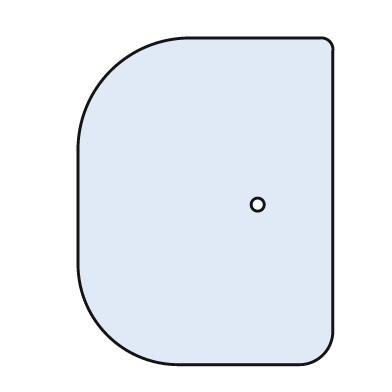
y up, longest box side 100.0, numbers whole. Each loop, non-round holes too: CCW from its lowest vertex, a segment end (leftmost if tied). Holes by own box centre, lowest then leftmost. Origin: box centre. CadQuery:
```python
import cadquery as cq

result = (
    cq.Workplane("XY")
    .moveTo(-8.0, -50.0)
    .lineTo(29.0, -50.0)
    .threePointArc((36.0, -47.0), (39.0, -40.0))
    .lineTo(39.0, 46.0)
    .threePointArc((38.0, 49.0), (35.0, 50.0))
    .lineTo(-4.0, 50.0)
    .threePointArc((-29.0, 40.0), (-39.0, 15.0))
    .lineTo(-39.0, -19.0)
    .threePointArc((-30.0, -41.0), (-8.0, -50.0))
    .close()
    .moveTo(16.0, -1.0)
    .circle(2.0)
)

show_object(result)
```